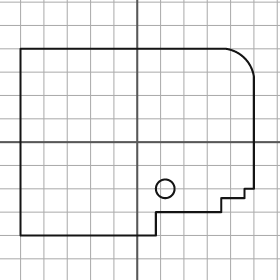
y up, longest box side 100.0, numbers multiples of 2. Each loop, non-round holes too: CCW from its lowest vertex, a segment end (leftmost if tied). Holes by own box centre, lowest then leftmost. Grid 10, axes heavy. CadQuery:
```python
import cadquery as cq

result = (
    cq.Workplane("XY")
    .moveTo(-50.0, -40.0)
    .lineTo(8.0, -40.0)
    .lineTo(8.0, -30.0)
    .lineTo(36.0, -30.0)
    .lineTo(36.0, -24.0)
    .lineTo(46.0, -24.0)
    .lineTo(46.0, -20.0)
    .lineTo(50.0, -20.0)
    .lineTo(50.0, 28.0)
    .threePointArc((46.0, 36.0), (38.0, 40.0))
    .lineTo(-50.0, 40.0)
    .close()
    .moveTo(12.0, -20.0)
    .circle(4.0)
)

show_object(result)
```